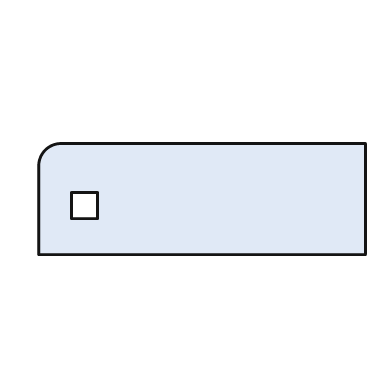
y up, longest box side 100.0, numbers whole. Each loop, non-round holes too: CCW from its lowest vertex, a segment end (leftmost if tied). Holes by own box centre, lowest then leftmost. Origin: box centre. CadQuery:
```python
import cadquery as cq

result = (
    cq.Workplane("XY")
    .moveTo(-50.0, -17.0)
    .lineTo(50.0, -17.0)
    .lineTo(50.0, 17.0)
    .lineTo(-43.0, 17.0)
    .threePointArc((-48.0, 15.0), (-50.0, 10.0))
    .close()
    .moveTo(-40.0, -6.0)
    .lineTo(-32.0, -6.0)
    .lineTo(-32.0, 2.0)
    .lineTo(-40.0, 2.0)
    .close()
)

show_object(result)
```